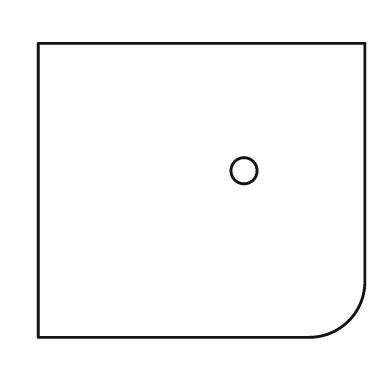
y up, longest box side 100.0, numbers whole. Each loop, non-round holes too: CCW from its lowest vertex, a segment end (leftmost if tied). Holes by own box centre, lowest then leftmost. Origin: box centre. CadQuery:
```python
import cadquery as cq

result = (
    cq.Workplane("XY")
    .moveTo(-50.0, -45.0)
    .lineTo(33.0, -45.0)
    .threePointArc((45.0, -40.0), (50.0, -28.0))
    .lineTo(50.0, 45.0)
    .lineTo(-50.0, 45.0)
    .close()
    .moveTo(13.0, 6.0)
    .circle(4.0)
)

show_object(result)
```